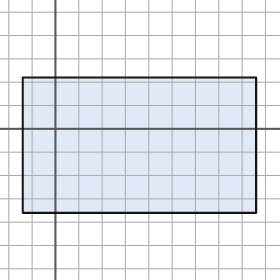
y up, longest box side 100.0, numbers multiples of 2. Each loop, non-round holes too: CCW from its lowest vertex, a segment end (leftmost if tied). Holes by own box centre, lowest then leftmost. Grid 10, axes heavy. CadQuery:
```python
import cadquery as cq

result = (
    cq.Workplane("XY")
    .moveTo(-14.0, -36.0)
    .lineTo(86.0, -36.0)
    .lineTo(86.0, 22.0)
    .lineTo(-14.0, 22.0)
    .close()
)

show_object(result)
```